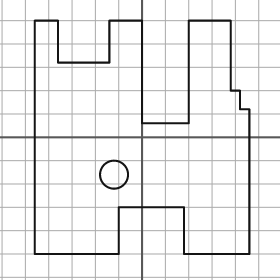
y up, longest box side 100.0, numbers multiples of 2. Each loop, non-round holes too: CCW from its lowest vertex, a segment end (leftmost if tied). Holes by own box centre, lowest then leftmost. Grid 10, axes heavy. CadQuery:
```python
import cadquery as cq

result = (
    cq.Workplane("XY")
    .moveTo(-46.0, -50.0)
    .lineTo(-10.0, -50.0)
    .lineTo(-10.0, -30.0)
    .lineTo(18.0, -30.0)
    .lineTo(18.0, -50.0)
    .lineTo(46.0, -50.0)
    .lineTo(46.0, 12.0)
    .lineTo(42.0, 12.0)
    .lineTo(42.0, 20.0)
    .lineTo(38.0, 20.0)
    .lineTo(38.0, 50.0)
    .lineTo(20.0, 50.0)
    .lineTo(20.0, 6.0)
    .lineTo(0.0, 6.0)
    .lineTo(0.0, 50.0)
    .lineTo(-14.0, 50.0)
    .lineTo(-14.0, 32.0)
    .lineTo(-36.0, 32.0)
    .lineTo(-36.0, 50.0)
    .lineTo(-46.0, 50.0)
    .close()
    .moveTo(-12.0, -16.0)
    .circle(6.0)
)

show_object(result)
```